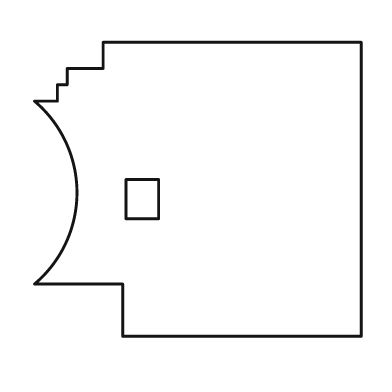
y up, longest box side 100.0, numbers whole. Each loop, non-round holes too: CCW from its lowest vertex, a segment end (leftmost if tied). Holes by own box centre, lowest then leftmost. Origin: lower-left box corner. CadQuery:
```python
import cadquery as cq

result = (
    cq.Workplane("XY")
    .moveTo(27.0, 0.0)
    .lineTo(100.0, 0.0)
    .lineTo(100.0, 90.0)
    .lineTo(21.0, 90.0)
    .lineTo(21.0, 82.0)
    .lineTo(10.0, 82.0)
    .lineTo(10.0, 77.0)
    .lineTo(7.0, 77.0)
    .lineTo(7.0, 72.0)
    .lineTo(0.0, 72.0)
    .threePointArc((13.0, 44.0), (0.0, 16.0))
    .lineTo(27.0, 16.0)
    .close()
    .moveTo(28.0, 36.0)
    .lineTo(38.0, 36.0)
    .lineTo(38.0, 48.0)
    .lineTo(28.0, 48.0)
    .close()
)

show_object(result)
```